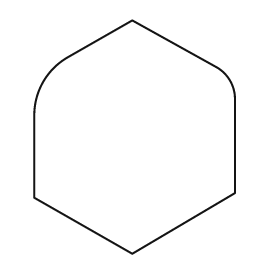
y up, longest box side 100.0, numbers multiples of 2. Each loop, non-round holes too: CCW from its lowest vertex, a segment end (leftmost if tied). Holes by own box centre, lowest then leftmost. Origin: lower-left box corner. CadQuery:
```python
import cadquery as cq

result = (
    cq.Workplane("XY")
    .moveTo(42.0, 0.0)
    .lineTo(86.0, 26.0)
    .lineTo(86.0, 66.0)
    .threePointArc((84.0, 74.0), (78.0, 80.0))
    .lineTo(42.0, 100.0)
    .lineTo(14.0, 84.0)
    .threePointArc((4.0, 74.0), (0.0, 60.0))
    .lineTo(0.0, 24.0)
    .close()
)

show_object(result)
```